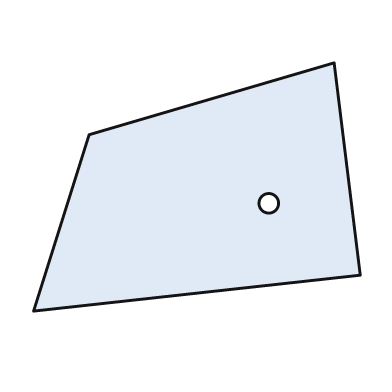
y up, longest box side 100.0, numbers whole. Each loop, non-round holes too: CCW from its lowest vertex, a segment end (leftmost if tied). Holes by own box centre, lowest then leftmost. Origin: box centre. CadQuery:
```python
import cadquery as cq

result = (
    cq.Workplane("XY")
    .moveTo(-50.0, -38.0)
    .lineTo(50.0, -27.0)
    .lineTo(42.0, 38.0)
    .lineTo(-33.0, 16.0)
    .close()
    .moveTo(22.0, -5.0)
    .circle(3.0)
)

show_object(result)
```